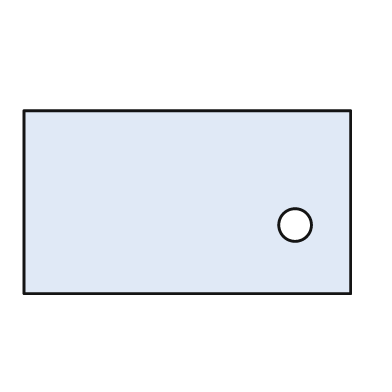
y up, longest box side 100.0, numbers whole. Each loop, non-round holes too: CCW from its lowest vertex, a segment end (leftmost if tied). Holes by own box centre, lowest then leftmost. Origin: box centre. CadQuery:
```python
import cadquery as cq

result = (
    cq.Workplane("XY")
    .moveTo(-50.0, -28.0)
    .lineTo(50.0, -28.0)
    .lineTo(50.0, 28.0)
    .lineTo(-50.0, 28.0)
    .close()
    .moveTo(33.0, -7.0)
    .circle(5.0)
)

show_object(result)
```